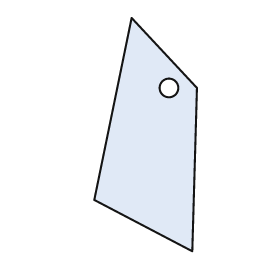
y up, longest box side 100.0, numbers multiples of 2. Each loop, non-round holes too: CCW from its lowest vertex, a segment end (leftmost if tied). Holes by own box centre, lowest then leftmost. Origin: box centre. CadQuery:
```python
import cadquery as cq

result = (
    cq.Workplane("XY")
    .moveTo(20.0, -50.0)
    .lineTo(22.0, 20.0)
    .lineTo(-6.0, 50.0)
    .lineTo(-22.0, -28.0)
    .close()
    .moveTo(10.0, 20.0)
    .circle(4.0)
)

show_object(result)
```